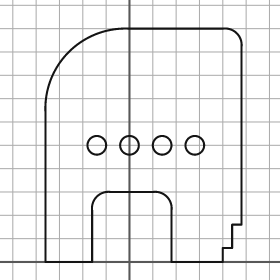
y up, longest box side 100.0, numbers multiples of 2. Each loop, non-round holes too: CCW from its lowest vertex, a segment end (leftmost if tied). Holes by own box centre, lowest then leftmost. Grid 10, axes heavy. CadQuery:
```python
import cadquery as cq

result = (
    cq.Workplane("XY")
    .moveTo(-36.0, 0.0)
    .lineTo(-16.0, 0.0)
    .lineTo(-16.0, 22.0)
    .threePointArc((-14.0, 28.0), (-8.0, 30.0))
    .lineTo(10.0, 30.0)
    .threePointArc((16.0, 28.0), (18.0, 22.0))
    .lineTo(18.0, 0.0)
    .lineTo(40.0, 0.0)
    .lineTo(40.0, 6.0)
    .lineTo(44.0, 6.0)
    .lineTo(44.0, 16.0)
    .lineTo(48.0, 16.0)
    .lineTo(48.0, 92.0)
    .threePointArc((46.0, 98.0), (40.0, 100.0))
    .lineTo(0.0, 100.0)
    .threePointArc((-26.0, 90.0), (-36.0, 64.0))
    .close()
    .moveTo(-14.0, 50.0)
    .circle(4.0)
    .moveTo(0.0, 50.0)
    .circle(4.0)
    .moveTo(14.0, 50.0)
    .circle(4.0)
    .moveTo(28.0, 50.0)
    .circle(4.0)
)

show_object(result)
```